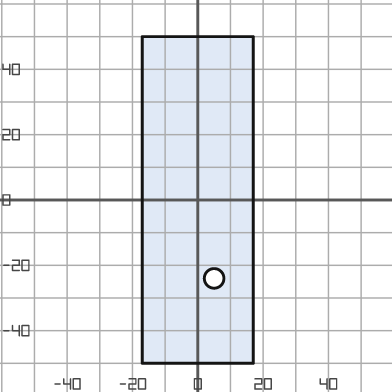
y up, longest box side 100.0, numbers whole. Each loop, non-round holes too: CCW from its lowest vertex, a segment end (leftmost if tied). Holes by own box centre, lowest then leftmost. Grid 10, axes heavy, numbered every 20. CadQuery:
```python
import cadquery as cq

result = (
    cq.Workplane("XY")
    .moveTo(-17.0, -50.0)
    .lineTo(17.0, -50.0)
    .lineTo(17.0, 50.0)
    .lineTo(-17.0, 50.0)
    .close()
    .moveTo(5.0, -24.0)
    .circle(3.0)
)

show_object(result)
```